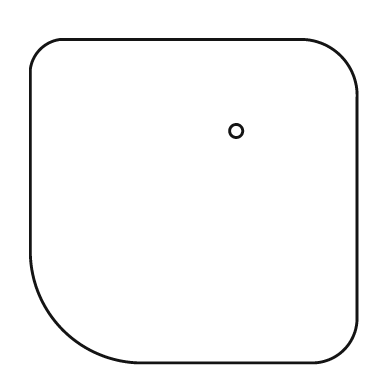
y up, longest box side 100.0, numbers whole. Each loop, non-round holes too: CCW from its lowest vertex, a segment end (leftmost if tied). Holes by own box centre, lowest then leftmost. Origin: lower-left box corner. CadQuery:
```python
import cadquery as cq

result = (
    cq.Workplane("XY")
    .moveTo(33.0, 0.0)
    .lineTo(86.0, 0.0)
    .threePointArc((96.0, 4.0), (100.0, 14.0))
    .lineTo(100.0, 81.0)
    .threePointArc((95.0, 94.0), (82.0, 99.0))
    .lineTo(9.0, 99.0)
    .threePointArc((3.0, 96.0), (0.0, 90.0))
    .lineTo(0.0, 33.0)
    .threePointArc((10.0, 10.0), (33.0, 0.0))
    .close()
    .moveTo(63.0, 71.0)
    .circle(2.0)
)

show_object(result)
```